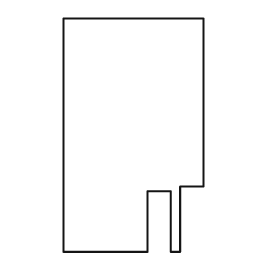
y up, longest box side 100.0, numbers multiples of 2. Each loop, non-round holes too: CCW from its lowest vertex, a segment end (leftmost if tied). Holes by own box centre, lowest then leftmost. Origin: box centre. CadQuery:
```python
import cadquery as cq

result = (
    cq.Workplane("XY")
    .moveTo(-30.0, -50.0)
    .lineTo(6.0, -50.0)
    .lineTo(6.0, -24.0)
    .lineTo(16.0, -24.0)
    .lineTo(16.0, -50.0)
    .lineTo(20.0, -50.0)
    .lineTo(20.0, -22.0)
    .lineTo(30.0, -22.0)
    .lineTo(30.0, 50.0)
    .lineTo(-30.0, 50.0)
    .close()
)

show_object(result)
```